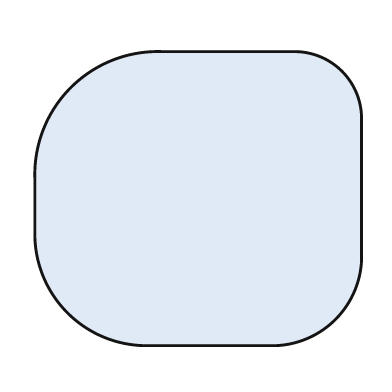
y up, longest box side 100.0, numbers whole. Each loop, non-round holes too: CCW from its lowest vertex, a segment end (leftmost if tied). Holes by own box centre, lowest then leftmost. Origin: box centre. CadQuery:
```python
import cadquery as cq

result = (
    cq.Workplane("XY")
    .moveTo(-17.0, -45.0)
    .lineTo(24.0, -45.0)
    .threePointArc((42.0, -37.0), (50.0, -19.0))
    .lineTo(50.0, 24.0)
    .threePointArc((44.0, 39.0), (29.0, 45.0))
    .lineTo(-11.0, 45.0)
    .threePointArc((-39.0, 34.0), (-50.0, 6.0))
    .lineTo(-50.0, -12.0)
    .threePointArc((-40.0, -35.0), (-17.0, -45.0))
    .close()
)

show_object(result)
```